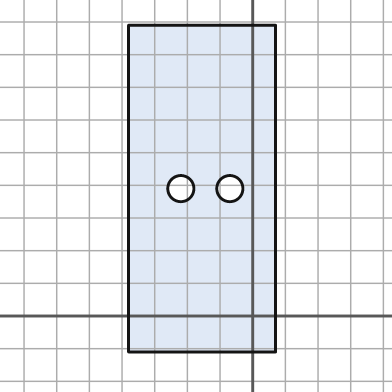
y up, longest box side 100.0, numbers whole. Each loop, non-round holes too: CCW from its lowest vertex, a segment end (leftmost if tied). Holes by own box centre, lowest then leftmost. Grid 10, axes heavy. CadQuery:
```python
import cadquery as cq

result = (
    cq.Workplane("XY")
    .moveTo(-38.0, -11.0)
    .lineTo(7.0, -11.0)
    .lineTo(7.0, 89.0)
    .lineTo(-38.0, 89.0)
    .close()
    .moveTo(-22.0, 39.0)
    .circle(4.0)
    .moveTo(-7.0, 39.0)
    .circle(4.0)
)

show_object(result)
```